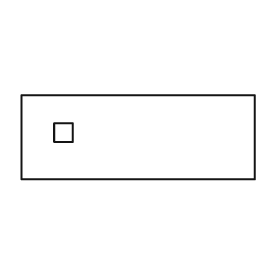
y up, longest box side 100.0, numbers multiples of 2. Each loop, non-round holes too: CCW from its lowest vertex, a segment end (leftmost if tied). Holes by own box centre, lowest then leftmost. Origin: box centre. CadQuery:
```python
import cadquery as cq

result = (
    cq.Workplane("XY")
    .moveTo(-50.0, -18.0)
    .lineTo(50.0, -18.0)
    .lineTo(50.0, 18.0)
    .lineTo(-50.0, 18.0)
    .close()
    .moveTo(-36.0, -2.0)
    .lineTo(-28.0, -2.0)
    .lineTo(-28.0, 6.0)
    .lineTo(-36.0, 6.0)
    .close()
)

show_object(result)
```